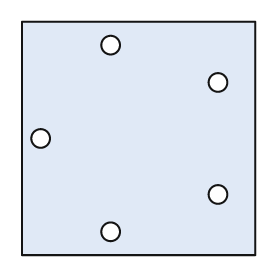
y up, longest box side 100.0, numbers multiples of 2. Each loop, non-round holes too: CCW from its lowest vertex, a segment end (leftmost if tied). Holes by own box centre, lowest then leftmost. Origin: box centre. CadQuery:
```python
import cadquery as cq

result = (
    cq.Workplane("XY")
    .moveTo(-50.0, -50.0)
    .lineTo(50.0, -50.0)
    .lineTo(50.0, 50.0)
    .lineTo(-50.0, 50.0)
    .close()
    .moveTo(-12.0, -40.0)
    .circle(4.0)
    .moveTo(34.0, -24.0)
    .circle(4.0)
    .moveTo(-42.0, 0.0)
    .circle(4.0)
    .moveTo(34.0, 24.0)
    .circle(4.0)
    .moveTo(-12.0, 40.0)
    .circle(4.0)
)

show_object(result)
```